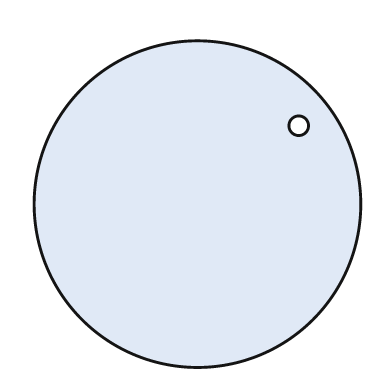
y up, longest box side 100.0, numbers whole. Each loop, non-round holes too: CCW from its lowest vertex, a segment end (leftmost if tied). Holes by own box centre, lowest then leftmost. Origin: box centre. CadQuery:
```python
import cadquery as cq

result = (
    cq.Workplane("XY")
    .moveTo(0.0, 0.0)
    .circle(50.0)
    .moveTo(31.0, 24.0)
    .circle(3.0)
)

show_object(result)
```